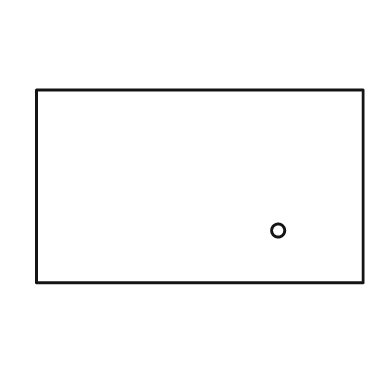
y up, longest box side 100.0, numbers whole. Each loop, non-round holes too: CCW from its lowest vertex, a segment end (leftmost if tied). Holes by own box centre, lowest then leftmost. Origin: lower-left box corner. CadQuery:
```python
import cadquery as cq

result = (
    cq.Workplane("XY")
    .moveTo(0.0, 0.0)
    .lineTo(100.0, 0.0)
    .lineTo(100.0, 59.0)
    .lineTo(0.0, 59.0)
    .close()
    .moveTo(74.0, 16.0)
    .circle(2.0)
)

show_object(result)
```